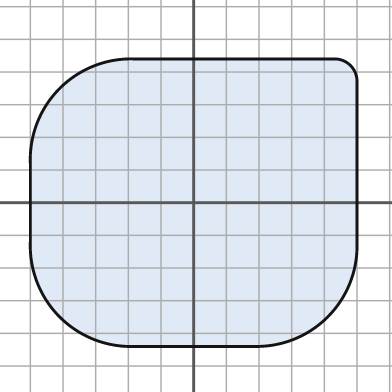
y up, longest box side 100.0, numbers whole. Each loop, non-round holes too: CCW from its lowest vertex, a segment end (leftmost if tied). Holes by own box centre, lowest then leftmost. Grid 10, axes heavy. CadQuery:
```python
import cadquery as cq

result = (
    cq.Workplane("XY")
    .moveTo(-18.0, -44.0)
    .lineTo(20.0, -44.0)
    .threePointArc((41.0, -35.0), (50.0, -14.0))
    .lineTo(50.0, 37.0)
    .threePointArc((48.0, 42.0), (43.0, 44.0))
    .lineTo(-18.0, 44.0)
    .threePointArc((-41.0, 35.0), (-50.0, 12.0))
    .lineTo(-50.0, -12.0)
    .threePointArc((-41.0, -35.0), (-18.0, -44.0))
    .close()
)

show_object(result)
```